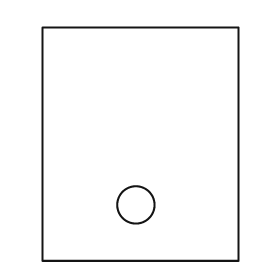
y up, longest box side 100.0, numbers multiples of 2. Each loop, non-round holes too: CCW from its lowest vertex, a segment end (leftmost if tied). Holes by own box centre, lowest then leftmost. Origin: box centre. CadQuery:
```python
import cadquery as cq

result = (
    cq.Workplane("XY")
    .moveTo(-42.0, -50.0)
    .lineTo(42.0, -50.0)
    .lineTo(42.0, 50.0)
    .lineTo(-42.0, 50.0)
    .close()
    .moveTo(-2.0, -26.0)
    .circle(8.0)
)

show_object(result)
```